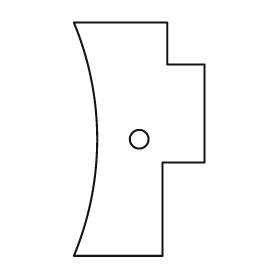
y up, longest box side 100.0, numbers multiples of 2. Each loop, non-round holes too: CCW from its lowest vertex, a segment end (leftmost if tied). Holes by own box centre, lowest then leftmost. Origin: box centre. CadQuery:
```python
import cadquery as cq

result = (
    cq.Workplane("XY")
    .moveTo(-28.0, -50.0)
    .lineTo(10.0, -50.0)
    .lineTo(10.0, -10.0)
    .lineTo(28.0, -10.0)
    .lineTo(28.0, 32.0)
    .lineTo(12.0, 32.0)
    .lineTo(12.0, 50.0)
    .lineTo(-28.0, 50.0)
    .threePointArc((-18.0, 0.0), (-28.0, -50.0))
    .close()
    .moveTo(0.0, 0.0)
    .circle(4.0)
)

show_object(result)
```